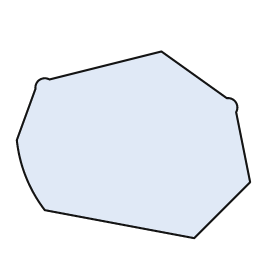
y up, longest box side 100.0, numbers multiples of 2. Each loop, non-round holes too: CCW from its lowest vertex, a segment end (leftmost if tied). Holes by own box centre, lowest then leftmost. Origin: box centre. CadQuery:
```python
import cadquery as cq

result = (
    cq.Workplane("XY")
    .moveTo(26.0, -40.0)
    .lineTo(50.0, -16.0)
    .lineTo(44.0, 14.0)
    .threePointArc((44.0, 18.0), (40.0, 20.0))
    .lineTo(12.0, 40.0)
    .lineTo(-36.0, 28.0)
    .threePointArc((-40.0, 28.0), (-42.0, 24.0))
    .lineTo(-50.0, 2.0)
    .threePointArc((-46.0, -14.0), (-38.0, -28.0))
    .close()
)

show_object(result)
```